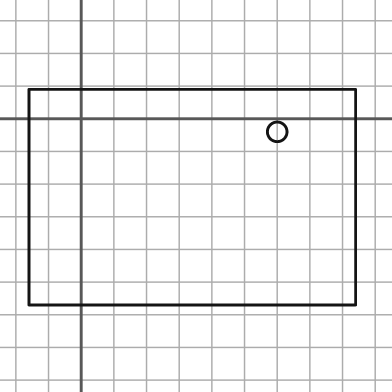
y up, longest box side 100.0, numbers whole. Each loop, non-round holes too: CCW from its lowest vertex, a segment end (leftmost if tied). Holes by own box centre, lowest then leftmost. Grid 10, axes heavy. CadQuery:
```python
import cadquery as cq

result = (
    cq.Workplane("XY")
    .moveTo(-16.0, -57.0)
    .lineTo(84.0, -57.0)
    .lineTo(84.0, 9.0)
    .lineTo(-16.0, 9.0)
    .close()
    .moveTo(60.0, -4.0)
    .circle(3.0)
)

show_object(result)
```